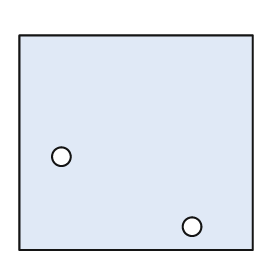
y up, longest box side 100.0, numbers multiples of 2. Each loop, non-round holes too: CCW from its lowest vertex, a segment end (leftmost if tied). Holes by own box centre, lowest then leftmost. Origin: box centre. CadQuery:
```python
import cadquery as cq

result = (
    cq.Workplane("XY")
    .moveTo(-50.0, -46.0)
    .lineTo(50.0, -46.0)
    .lineTo(50.0, 46.0)
    .lineTo(-50.0, 46.0)
    .close()
    .moveTo(24.0, -36.0)
    .circle(4.0)
    .moveTo(-32.0, -6.0)
    .circle(4.0)
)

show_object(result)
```